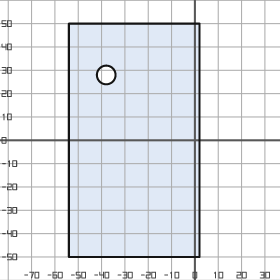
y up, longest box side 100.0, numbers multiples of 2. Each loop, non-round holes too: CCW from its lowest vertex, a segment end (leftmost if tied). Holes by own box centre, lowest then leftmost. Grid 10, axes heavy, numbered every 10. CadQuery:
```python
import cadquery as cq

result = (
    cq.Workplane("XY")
    .moveTo(-54.0, -50.0)
    .lineTo(2.0, -50.0)
    .lineTo(2.0, 50.0)
    .lineTo(-54.0, 50.0)
    .close()
    .moveTo(-38.0, 28.0)
    .circle(4.0)
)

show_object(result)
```